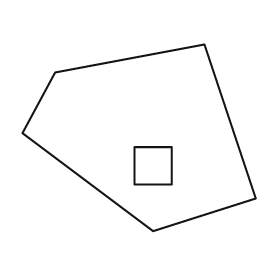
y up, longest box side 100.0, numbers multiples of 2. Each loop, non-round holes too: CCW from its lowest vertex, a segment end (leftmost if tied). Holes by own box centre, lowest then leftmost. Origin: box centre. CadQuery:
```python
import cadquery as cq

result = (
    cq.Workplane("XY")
    .moveTo(6.0, -40.0)
    .lineTo(50.0, -26.0)
    .lineTo(28.0, 40.0)
    .lineTo(-36.0, 28.0)
    .lineTo(-50.0, 2.0)
    .close()
    .moveTo(-2.0, -20.0)
    .lineTo(14.0, -20.0)
    .lineTo(14.0, -4.0)
    .lineTo(-2.0, -4.0)
    .close()
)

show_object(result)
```